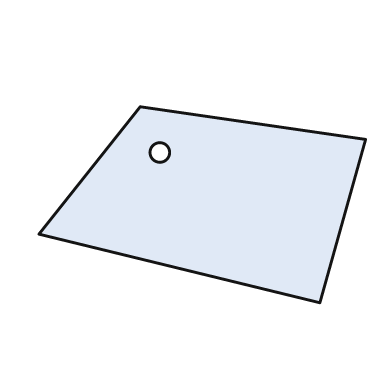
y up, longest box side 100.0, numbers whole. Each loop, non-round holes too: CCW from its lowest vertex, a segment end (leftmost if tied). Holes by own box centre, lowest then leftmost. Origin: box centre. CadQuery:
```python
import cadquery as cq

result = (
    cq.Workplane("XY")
    .moveTo(36.0, -30.0)
    .lineTo(50.0, 20.0)
    .lineTo(-19.0, 30.0)
    .lineTo(-50.0, -9.0)
    .close()
    .moveTo(-13.0, 16.0)
    .circle(3.0)
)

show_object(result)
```